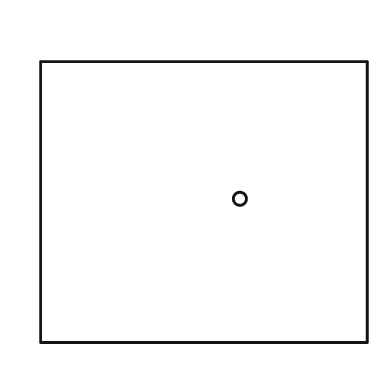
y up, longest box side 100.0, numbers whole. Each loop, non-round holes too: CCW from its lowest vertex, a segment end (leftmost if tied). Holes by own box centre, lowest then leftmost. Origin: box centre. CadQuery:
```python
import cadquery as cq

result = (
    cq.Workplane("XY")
    .moveTo(-50.0, -43.0)
    .lineTo(50.0, -43.0)
    .lineTo(50.0, 43.0)
    .lineTo(-50.0, 43.0)
    .close()
    .moveTo(11.0, 1.0)
    .circle(2.0)
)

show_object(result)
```